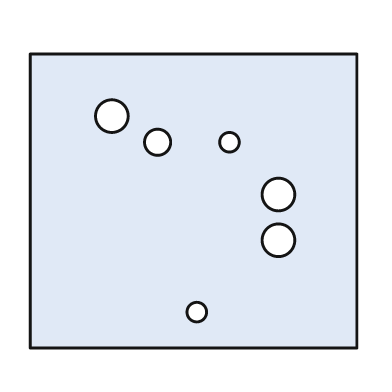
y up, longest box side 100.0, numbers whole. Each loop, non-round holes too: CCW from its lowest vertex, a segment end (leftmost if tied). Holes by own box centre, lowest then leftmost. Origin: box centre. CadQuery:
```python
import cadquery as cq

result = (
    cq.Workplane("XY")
    .moveTo(-50.0, -45.0)
    .lineTo(50.0, -45.0)
    .lineTo(50.0, 45.0)
    .lineTo(-50.0, 45.0)
    .close()
    .moveTo(1.0, -34.0)
    .circle(3.0)
    .moveTo(26.0, -12.0)
    .circle(5.0)
    .moveTo(26.0, 2.0)
    .circle(5.0)
    .moveTo(-11.0, 18.0)
    .circle(4.0)
    .moveTo(11.0, 18.0)
    .circle(3.0)
    .moveTo(-25.0, 26.0)
    .circle(5.0)
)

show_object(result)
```